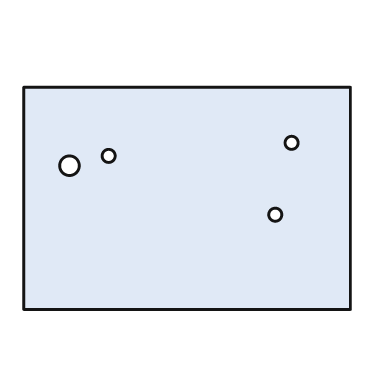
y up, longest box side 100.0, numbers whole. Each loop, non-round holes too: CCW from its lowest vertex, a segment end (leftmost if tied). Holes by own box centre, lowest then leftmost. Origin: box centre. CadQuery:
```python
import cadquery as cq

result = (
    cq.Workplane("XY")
    .moveTo(-50.0, -34.0)
    .lineTo(50.0, -34.0)
    .lineTo(50.0, 34.0)
    .lineTo(-50.0, 34.0)
    .close()
    .moveTo(27.0, -5.0)
    .circle(2.0)
    .moveTo(-36.0, 10.0)
    .circle(3.0)
    .moveTo(-24.0, 13.0)
    .circle(2.0)
    .moveTo(32.0, 17.0)
    .circle(2.0)
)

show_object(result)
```